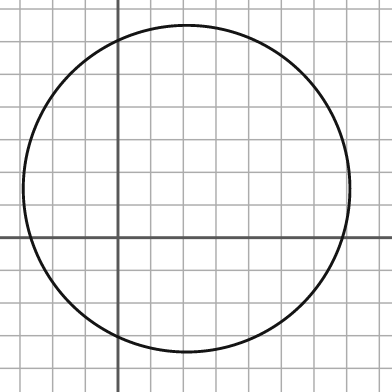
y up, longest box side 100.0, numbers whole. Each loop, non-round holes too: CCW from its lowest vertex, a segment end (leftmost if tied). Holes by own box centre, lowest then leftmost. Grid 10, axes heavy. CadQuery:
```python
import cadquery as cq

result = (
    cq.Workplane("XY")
    .moveTo(21.0, 15.0)
    .circle(50.0)
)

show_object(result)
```